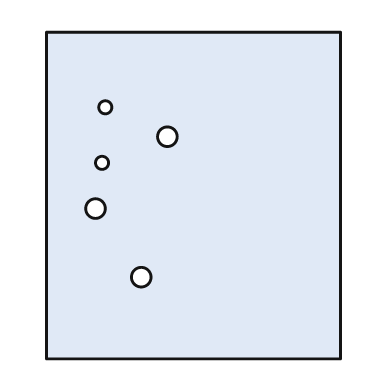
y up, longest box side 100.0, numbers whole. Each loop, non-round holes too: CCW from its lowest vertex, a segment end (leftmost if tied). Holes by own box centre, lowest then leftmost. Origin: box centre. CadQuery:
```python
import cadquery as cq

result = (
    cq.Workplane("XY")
    .moveTo(-45.0, -50.0)
    .lineTo(45.0, -50.0)
    .lineTo(45.0, 50.0)
    .lineTo(-45.0, 50.0)
    .close()
    .moveTo(-16.0, -25.0)
    .circle(3.0)
    .moveTo(-30.0, -4.0)
    .circle(3.0)
    .moveTo(-28.0, 10.0)
    .circle(2.0)
    .moveTo(-8.0, 18.0)
    .circle(3.0)
    .moveTo(-27.0, 27.0)
    .circle(2.0)
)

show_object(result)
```